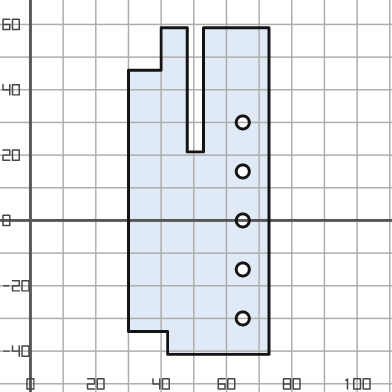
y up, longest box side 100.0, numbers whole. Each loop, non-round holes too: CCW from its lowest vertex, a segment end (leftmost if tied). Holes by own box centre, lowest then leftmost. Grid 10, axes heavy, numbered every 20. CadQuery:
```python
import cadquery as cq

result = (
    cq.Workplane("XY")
    .moveTo(42.0, -41.0)
    .lineTo(73.0, -41.0)
    .lineTo(73.0, 59.0)
    .lineTo(53.0, 59.0)
    .lineTo(53.0, 21.0)
    .lineTo(48.0, 21.0)
    .lineTo(48.0, 59.0)
    .lineTo(40.0, 59.0)
    .lineTo(40.0, 46.0)
    .lineTo(30.0, 46.0)
    .lineTo(30.0, -34.0)
    .lineTo(42.0, -34.0)
    .close()
    .moveTo(65.0, -30.0)
    .circle(2.0)
    .moveTo(65.0, -15.0)
    .circle(2.0)
    .moveTo(65.0, 0.0)
    .circle(2.0)
    .moveTo(65.0, 15.0)
    .circle(2.0)
    .moveTo(65.0, 30.0)
    .circle(2.0)
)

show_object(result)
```